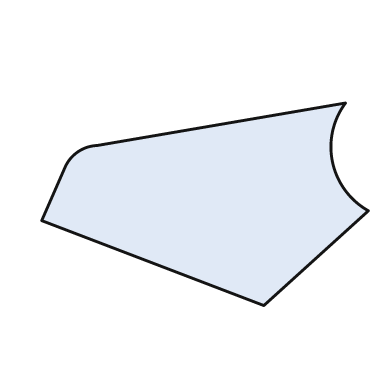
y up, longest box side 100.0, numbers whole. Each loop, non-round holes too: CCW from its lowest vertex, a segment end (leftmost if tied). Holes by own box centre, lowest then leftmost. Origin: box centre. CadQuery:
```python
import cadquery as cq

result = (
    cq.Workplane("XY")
    .moveTo(18.0, -31.0)
    .lineTo(50.0, -2.0)
    .threePointArc((39.0, 13.0), (43.0, 31.0))
    .lineTo(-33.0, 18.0)
    .threePointArc((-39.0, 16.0), (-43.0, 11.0))
    .lineTo(-50.0, -5.0)
    .close()
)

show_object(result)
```